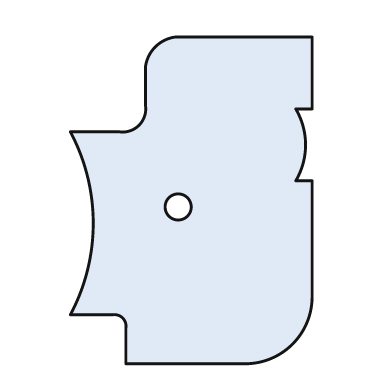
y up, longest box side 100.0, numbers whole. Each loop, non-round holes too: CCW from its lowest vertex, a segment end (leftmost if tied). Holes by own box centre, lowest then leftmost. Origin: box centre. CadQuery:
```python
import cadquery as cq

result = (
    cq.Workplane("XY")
    .moveTo(-20.0, -50.0)
    .lineTo(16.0, -50.0)
    .threePointArc((31.0, -44.0), (37.0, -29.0))
    .lineTo(37.0, 6.0)
    .lineTo(32.0, 6.0)
    .threePointArc((35.0, 17.0), (32.0, 28.0))
    .lineTo(37.0, 28.0)
    .lineTo(37.0, 50.0)
    .lineTo(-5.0, 50.0)
    .threePointArc((-11.0, 47.0), (-14.0, 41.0))
    .lineTo(-14.0, 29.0)
    .threePointArc((-16.0, 23.0), (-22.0, 21.0))
    .lineTo(-37.0, 21.0)
    .threePointArc((-30.0, -7.0), (-37.0, -35.0))
    .lineTo(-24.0, -35.0)
    .threePointArc((-21.0, -36.0), (-20.0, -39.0))
    .close()
    .moveTo(-4.0, -2.0)
    .circle(4.0)
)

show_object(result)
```